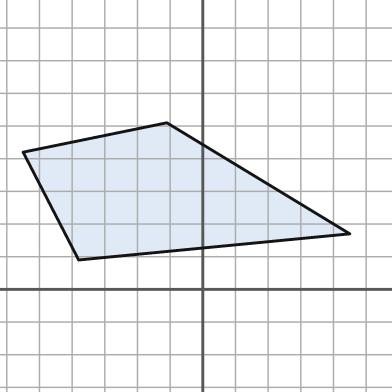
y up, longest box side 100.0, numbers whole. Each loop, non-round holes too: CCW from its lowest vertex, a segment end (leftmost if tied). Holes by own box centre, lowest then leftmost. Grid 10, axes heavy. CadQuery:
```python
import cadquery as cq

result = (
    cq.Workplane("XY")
    .moveTo(-38.0, 9.0)
    .lineTo(45.0, 17.0)
    .lineTo(-11.0, 51.0)
    .lineTo(-55.0, 42.0)
    .close()
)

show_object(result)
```